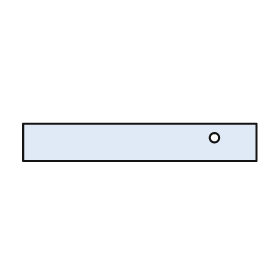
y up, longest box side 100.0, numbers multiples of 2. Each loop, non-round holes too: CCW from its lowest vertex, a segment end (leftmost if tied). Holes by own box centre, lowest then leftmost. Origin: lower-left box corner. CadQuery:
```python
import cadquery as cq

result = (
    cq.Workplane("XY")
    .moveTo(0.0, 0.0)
    .lineTo(100.0, 0.0)
    .lineTo(100.0, 16.0)
    .lineTo(0.0, 16.0)
    .close()
    .moveTo(82.0, 10.0)
    .circle(2.0)
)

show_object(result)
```